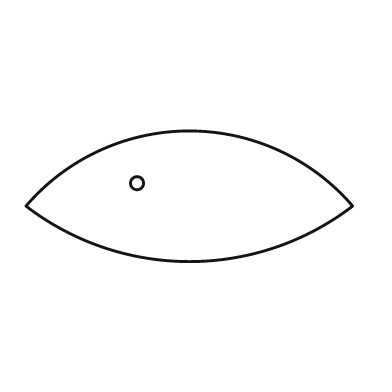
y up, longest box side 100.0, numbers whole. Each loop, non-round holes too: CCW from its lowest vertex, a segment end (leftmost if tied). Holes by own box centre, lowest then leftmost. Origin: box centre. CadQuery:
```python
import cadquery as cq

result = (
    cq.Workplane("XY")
    .moveTo(-50.0, -3.0)
    .threePointArc((0.0, -20.0), (50.0, -3.0))
    .threePointArc((0.0, 20.0), (-50.0, -3.0))
    .close()
    .moveTo(-16.0, 4.0)
    .circle(2.0)
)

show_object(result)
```